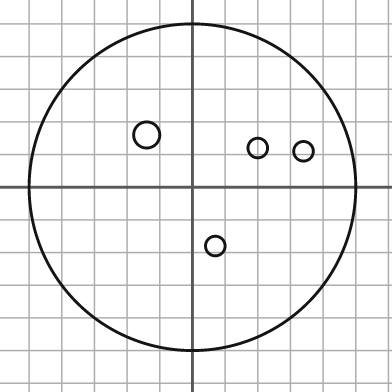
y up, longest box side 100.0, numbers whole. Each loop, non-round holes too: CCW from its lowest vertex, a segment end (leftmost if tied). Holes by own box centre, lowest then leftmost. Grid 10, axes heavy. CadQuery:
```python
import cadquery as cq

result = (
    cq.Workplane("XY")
    .moveTo(0.0, 0.0)
    .circle(50.0)
    .moveTo(7.0, -18.0)
    .circle(3.0)
    .moveTo(34.0, 11.0)
    .circle(3.0)
    .moveTo(20.0, 12.0)
    .circle(3.0)
    .moveTo(-14.0, 16.0)
    .circle(4.0)
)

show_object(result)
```